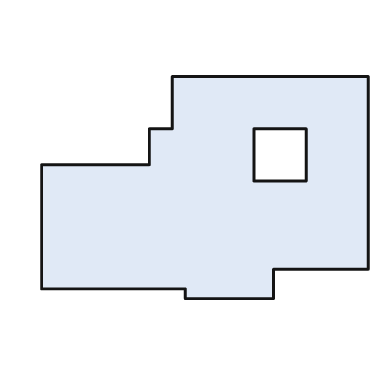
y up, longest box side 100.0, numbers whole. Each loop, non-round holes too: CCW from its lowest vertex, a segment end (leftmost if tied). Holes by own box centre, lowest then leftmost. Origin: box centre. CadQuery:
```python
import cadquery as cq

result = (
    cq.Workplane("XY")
    .moveTo(-6.0, -34.0)
    .lineTo(21.0, -34.0)
    .lineTo(21.0, -25.0)
    .lineTo(50.0, -25.0)
    .lineTo(50.0, 34.0)
    .lineTo(-10.0, 34.0)
    .lineTo(-10.0, 18.0)
    .lineTo(-17.0, 18.0)
    .lineTo(-17.0, 7.0)
    .lineTo(-50.0, 7.0)
    .lineTo(-50.0, -31.0)
    .lineTo(-6.0, -31.0)
    .close()
    .moveTo(15.0, 2.0)
    .lineTo(31.0, 2.0)
    .lineTo(31.0, 18.0)
    .lineTo(15.0, 18.0)
    .close()
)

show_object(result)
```